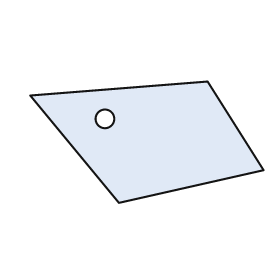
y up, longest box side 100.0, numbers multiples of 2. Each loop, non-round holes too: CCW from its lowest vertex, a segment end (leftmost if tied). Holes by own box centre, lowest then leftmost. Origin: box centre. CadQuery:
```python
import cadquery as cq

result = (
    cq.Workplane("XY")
    .moveTo(-12.0, -26.0)
    .lineTo(50.0, -12.0)
    .lineTo(26.0, 26.0)
    .lineTo(-50.0, 20.0)
    .close()
    .moveTo(-18.0, 10.0)
    .circle(4.0)
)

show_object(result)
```